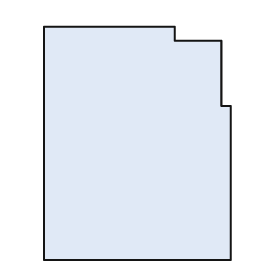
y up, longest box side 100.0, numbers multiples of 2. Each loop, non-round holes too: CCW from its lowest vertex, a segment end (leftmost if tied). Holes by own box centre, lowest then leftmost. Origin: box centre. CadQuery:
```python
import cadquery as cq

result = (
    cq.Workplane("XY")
    .moveTo(-40.0, -50.0)
    .lineTo(40.0, -50.0)
    .lineTo(40.0, 16.0)
    .lineTo(36.0, 16.0)
    .lineTo(36.0, 44.0)
    .lineTo(16.0, 44.0)
    .lineTo(16.0, 50.0)
    .lineTo(-40.0, 50.0)
    .close()
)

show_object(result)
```